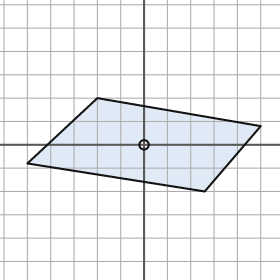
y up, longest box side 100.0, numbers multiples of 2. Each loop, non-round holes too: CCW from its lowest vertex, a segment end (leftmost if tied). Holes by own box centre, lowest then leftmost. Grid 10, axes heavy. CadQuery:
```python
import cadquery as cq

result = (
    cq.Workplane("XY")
    .moveTo(26.0, -20.0)
    .lineTo(50.0, 8.0)
    .lineTo(-20.0, 20.0)
    .lineTo(-50.0, -8.0)
    .close()
    .moveTo(0.0, 0.0)
    .circle(2.0)
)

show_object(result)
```